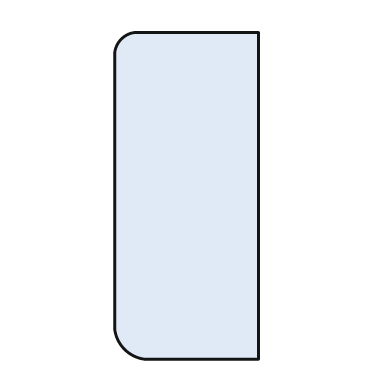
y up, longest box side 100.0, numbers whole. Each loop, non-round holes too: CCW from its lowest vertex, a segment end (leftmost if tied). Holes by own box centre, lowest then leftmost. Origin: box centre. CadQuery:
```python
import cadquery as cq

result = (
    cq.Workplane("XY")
    .moveTo(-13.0, -50.0)
    .lineTo(22.0, -50.0)
    .lineTo(22.0, 50.0)
    .lineTo(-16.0, 50.0)
    .threePointArc((-20.0, 48.0), (-22.0, 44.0))
    .lineTo(-22.0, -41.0)
    .threePointArc((-19.0, -47.0), (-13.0, -50.0))
    .close()
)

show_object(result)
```